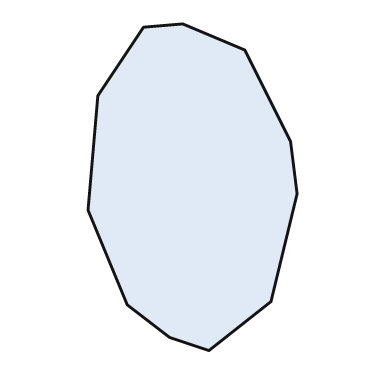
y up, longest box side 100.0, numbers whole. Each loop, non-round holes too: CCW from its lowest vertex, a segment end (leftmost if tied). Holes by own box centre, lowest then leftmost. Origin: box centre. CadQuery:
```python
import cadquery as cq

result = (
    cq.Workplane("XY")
    .moveTo(5.0, -50.0)
    .lineTo(24.0, -35.0)
    .lineTo(32.0, -2.0)
    .lineTo(30.0, 14.0)
    .lineTo(16.0, 42.0)
    .lineTo(-3.0, 50.0)
    .lineTo(-15.0, 49.0)
    .lineTo(-29.0, 28.0)
    .lineTo(-32.0, -7.0)
    .lineTo(-20.0, -36.0)
    .lineTo(-7.0, -46.0)
    .close()
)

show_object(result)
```